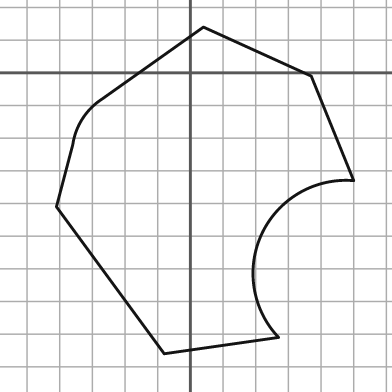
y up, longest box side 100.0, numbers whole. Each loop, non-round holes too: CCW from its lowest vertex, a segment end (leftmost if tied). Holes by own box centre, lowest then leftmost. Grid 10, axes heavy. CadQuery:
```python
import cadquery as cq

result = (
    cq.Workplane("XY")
    .moveTo(-8.0, -86.0)
    .lineTo(27.0, -81.0)
    .threePointArc((22.0, -49.0), (50.0, -33.0))
    .lineTo(37.0, -1.0)
    .lineTo(4.0, 14.0)
    .lineTo(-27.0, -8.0)
    .threePointArc((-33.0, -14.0), (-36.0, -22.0))
    .lineTo(-41.0, -41.0)
    .close()
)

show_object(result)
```